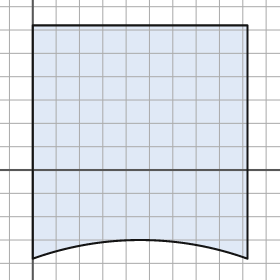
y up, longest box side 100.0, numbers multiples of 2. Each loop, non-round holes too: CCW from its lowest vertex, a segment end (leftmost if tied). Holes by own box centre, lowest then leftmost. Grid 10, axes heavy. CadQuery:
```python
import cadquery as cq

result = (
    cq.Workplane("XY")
    .moveTo(0.0, -38.0)
    .threePointArc((46.0, -30.0), (92.0, -38.0))
    .lineTo(92.0, 62.0)
    .lineTo(0.0, 62.0)
    .close()
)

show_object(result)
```